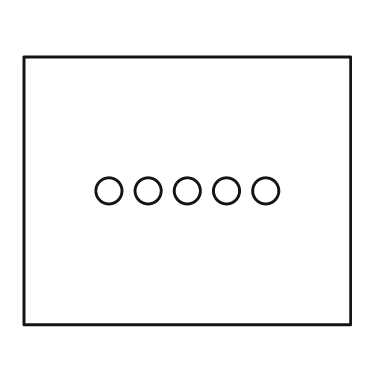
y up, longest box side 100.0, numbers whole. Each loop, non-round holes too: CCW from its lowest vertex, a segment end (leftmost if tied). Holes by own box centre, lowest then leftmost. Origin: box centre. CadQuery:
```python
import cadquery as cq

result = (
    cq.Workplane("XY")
    .moveTo(-50.0, -41.0)
    .lineTo(50.0, -41.0)
    .lineTo(50.0, 41.0)
    .lineTo(-50.0, 41.0)
    .close()
    .moveTo(-24.0, 0.0)
    .circle(4.0)
    .moveTo(-12.0, 0.0)
    .circle(4.0)
    .moveTo(0.0, 0.0)
    .circle(4.0)
    .moveTo(12.0, 0.0)
    .circle(4.0)
    .moveTo(24.0, 0.0)
    .circle(4.0)
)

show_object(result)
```